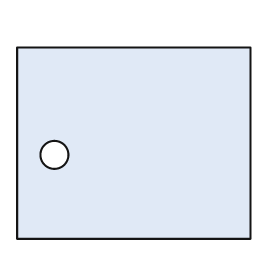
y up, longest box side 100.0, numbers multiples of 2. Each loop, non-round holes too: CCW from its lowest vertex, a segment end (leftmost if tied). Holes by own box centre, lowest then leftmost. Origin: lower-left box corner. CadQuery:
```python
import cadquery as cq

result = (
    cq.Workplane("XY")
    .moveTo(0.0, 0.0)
    .lineTo(100.0, 0.0)
    .lineTo(100.0, 82.0)
    .lineTo(0.0, 82.0)
    .close()
    .moveTo(16.0, 36.0)
    .circle(6.0)
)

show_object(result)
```